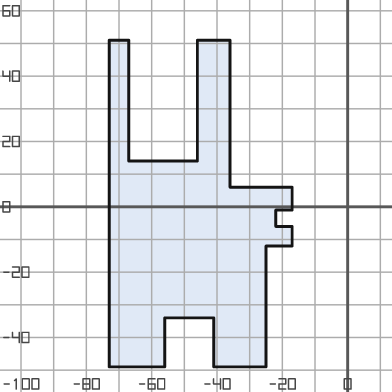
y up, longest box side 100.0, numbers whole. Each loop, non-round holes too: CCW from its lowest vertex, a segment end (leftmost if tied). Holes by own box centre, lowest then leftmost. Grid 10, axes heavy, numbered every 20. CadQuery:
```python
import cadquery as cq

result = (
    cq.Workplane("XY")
    .moveTo(-73.0, -49.0)
    .lineTo(-56.0, -49.0)
    .lineTo(-56.0, -34.0)
    .lineTo(-41.0, -34.0)
    .lineTo(-41.0, -49.0)
    .lineTo(-25.0, -49.0)
    .lineTo(-25.0, -12.0)
    .lineTo(-17.0, -12.0)
    .lineTo(-17.0, -6.0)
    .lineTo(-22.0, -6.0)
    .lineTo(-22.0, -1.0)
    .lineTo(-17.0, -1.0)
    .lineTo(-17.0, 6.0)
    .lineTo(-36.0, 6.0)
    .lineTo(-36.0, 51.0)
    .lineTo(-46.0, 51.0)
    .lineTo(-46.0, 14.0)
    .lineTo(-67.0, 14.0)
    .lineTo(-67.0, 51.0)
    .lineTo(-73.0, 51.0)
    .close()
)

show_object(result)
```